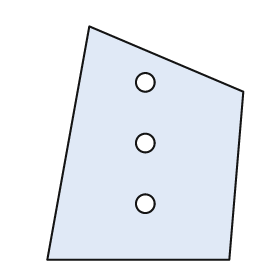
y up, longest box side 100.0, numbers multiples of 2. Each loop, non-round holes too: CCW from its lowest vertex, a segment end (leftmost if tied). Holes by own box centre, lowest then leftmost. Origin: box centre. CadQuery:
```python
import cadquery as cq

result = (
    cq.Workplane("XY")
    .moveTo(-42.0, -50.0)
    .lineTo(36.0, -50.0)
    .lineTo(42.0, 22.0)
    .lineTo(-24.0, 50.0)
    .close()
    .moveTo(0.0, -26.0)
    .circle(4.0)
    .moveTo(0.0, 0.0)
    .circle(4.0)
    .moveTo(0.0, 26.0)
    .circle(4.0)
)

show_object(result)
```